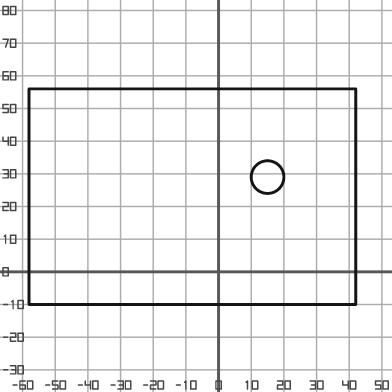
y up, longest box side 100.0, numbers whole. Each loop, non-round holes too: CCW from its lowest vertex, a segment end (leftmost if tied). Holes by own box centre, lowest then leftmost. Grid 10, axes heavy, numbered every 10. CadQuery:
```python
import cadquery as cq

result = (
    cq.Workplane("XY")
    .moveTo(-58.0, -10.0)
    .lineTo(42.0, -10.0)
    .lineTo(42.0, 56.0)
    .lineTo(-58.0, 56.0)
    .close()
    .moveTo(15.0, 29.0)
    .circle(5.0)
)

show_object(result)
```